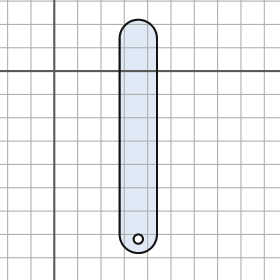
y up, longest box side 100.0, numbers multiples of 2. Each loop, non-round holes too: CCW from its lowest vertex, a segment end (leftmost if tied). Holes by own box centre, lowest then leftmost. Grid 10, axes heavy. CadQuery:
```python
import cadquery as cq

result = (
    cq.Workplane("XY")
    .moveTo(28.0, -70.0)
    .threePointArc((36.0, -78.0), (44.0, -70.0))
    .lineTo(44.0, 14.0)
    .threePointArc((36.0, 22.0), (28.0, 14.0))
    .close()
    .moveTo(36.0, -72.0)
    .circle(2.0)
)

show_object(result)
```